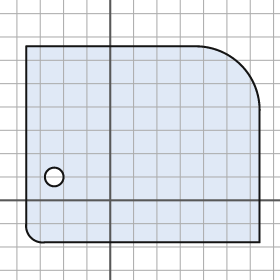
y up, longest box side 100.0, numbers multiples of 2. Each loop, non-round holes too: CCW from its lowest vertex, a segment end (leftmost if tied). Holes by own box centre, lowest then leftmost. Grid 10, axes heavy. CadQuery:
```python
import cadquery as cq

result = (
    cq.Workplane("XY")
    .moveTo(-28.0, -18.0)
    .lineTo(64.0, -18.0)
    .lineTo(64.0, 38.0)
    .threePointArc((56.0, 58.0), (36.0, 66.0))
    .lineTo(-36.0, 66.0)
    .lineTo(-36.0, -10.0)
    .threePointArc((-34.0, -16.0), (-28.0, -18.0))
    .close()
    .moveTo(-24.0, 10.0)
    .circle(4.0)
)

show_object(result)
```